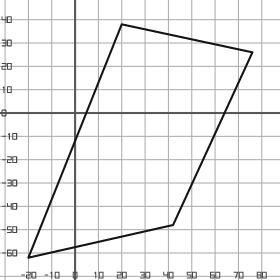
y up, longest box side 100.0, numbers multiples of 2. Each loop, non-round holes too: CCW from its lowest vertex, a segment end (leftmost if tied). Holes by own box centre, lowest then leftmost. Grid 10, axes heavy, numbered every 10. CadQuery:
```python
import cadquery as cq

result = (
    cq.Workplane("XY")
    .moveTo(-20.0, -62.0)
    .lineTo(42.0, -48.0)
    .lineTo(76.0, 26.0)
    .lineTo(20.0, 38.0)
    .close()
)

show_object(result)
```